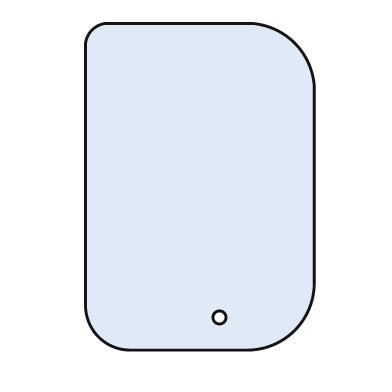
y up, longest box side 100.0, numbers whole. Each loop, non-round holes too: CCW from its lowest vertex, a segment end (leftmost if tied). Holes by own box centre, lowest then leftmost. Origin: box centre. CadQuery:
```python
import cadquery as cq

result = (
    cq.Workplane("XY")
    .moveTo(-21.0, -50.0)
    .lineTo(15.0, -50.0)
    .threePointArc((29.0, -44.0), (35.0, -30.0))
    .lineTo(35.0, 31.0)
    .threePointArc((29.0, 44.0), (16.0, 50.0))
    .lineTo(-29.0, 50.0)
    .threePointArc((-33.0, 48.0), (-35.0, 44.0))
    .lineTo(-35.0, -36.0)
    .threePointArc((-31.0, -46.0), (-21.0, -50.0))
    .close()
    .moveTo(6.0, -40.0)
    .circle(2.0)
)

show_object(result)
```